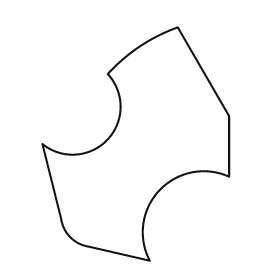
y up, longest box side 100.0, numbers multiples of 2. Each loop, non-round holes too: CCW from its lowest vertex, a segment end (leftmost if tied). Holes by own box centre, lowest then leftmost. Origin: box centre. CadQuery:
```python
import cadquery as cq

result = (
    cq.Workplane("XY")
    .moveTo(6.0, -50.0)
    .threePointArc((10.0, -20.0), (40.0, -14.0))
    .lineTo(40.0, 12.0)
    .lineTo(18.0, 50.0)
    .threePointArc((2.0, 42.0), (-12.0, 30.0))
    .threePointArc((-12.0, 2.0), (-40.0, 0.0))
    .lineTo(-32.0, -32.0)
    .threePointArc((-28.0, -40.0), (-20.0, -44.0))
    .close()
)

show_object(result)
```